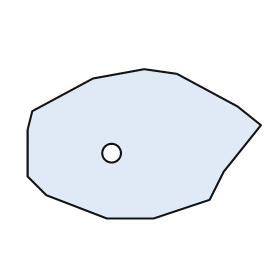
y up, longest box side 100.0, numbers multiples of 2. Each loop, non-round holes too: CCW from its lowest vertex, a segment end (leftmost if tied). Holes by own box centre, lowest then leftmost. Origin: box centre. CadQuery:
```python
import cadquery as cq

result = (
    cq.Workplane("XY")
    .moveTo(-16.0, -32.0)
    .lineTo(4.0, -32.0)
    .lineTo(28.0, -24.0)
    .lineTo(34.0, -12.0)
    .lineTo(50.0, 8.0)
    .lineTo(40.0, 16.0)
    .lineTo(14.0, 30.0)
    .lineTo(0.0, 32.0)
    .lineTo(-22.0, 28.0)
    .lineTo(-48.0, 14.0)
    .lineTo(-50.0, 6.0)
    .lineTo(-50.0, -14.0)
    .lineTo(-42.0, -22.0)
    .close()
    .moveTo(-14.0, -4.0)
    .circle(4.0)
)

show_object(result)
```